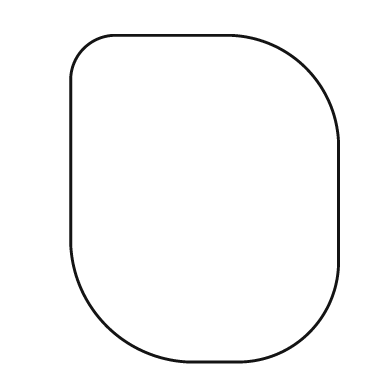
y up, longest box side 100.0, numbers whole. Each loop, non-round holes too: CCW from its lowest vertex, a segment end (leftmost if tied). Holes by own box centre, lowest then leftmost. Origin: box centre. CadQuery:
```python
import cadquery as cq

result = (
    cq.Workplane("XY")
    .moveTo(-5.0, -50.0)
    .lineTo(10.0, -50.0)
    .threePointArc((32.0, -41.0), (41.0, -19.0))
    .lineTo(41.0, 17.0)
    .threePointArc((31.0, 40.0), (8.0, 50.0))
    .lineTo(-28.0, 50.0)
    .threePointArc((-37.0, 46.0), (-41.0, 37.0))
    .lineTo(-41.0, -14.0)
    .threePointArc((-30.0, -39.0), (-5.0, -50.0))
    .close()
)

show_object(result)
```